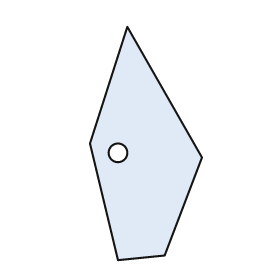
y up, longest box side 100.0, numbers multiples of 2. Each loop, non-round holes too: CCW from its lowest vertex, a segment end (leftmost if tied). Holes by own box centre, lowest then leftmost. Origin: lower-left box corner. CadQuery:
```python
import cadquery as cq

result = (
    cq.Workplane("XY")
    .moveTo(12.0, 0.0)
    .lineTo(32.0, 2.0)
    .lineTo(48.0, 44.0)
    .lineTo(16.0, 100.0)
    .lineTo(0.0, 50.0)
    .close()
    .moveTo(12.0, 46.0)
    .circle(4.0)
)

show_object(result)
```